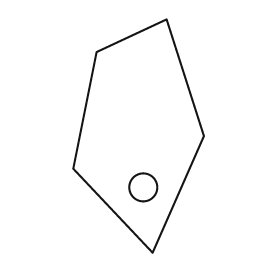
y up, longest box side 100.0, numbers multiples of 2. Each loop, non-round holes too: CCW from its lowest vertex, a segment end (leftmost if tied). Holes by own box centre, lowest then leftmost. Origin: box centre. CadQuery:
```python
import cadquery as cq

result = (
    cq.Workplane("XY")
    .moveTo(6.0, -50.0)
    .lineTo(28.0, 0.0)
    .lineTo(12.0, 50.0)
    .lineTo(-18.0, 36.0)
    .lineTo(-28.0, -14.0)
    .close()
    .moveTo(2.0, -22.0)
    .circle(6.0)
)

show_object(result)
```